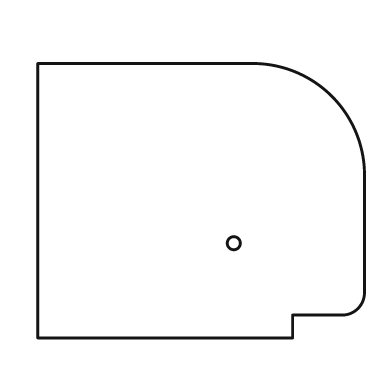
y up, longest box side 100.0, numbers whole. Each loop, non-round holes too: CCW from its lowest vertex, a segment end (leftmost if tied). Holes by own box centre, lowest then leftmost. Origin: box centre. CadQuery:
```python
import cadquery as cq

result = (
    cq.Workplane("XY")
    .moveTo(-50.0, -42.0)
    .lineTo(28.0, -42.0)
    .lineTo(28.0, -35.0)
    .lineTo(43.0, -35.0)
    .threePointArc((48.0, -33.0), (50.0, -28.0))
    .lineTo(50.0, 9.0)
    .threePointArc((40.0, 32.0), (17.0, 42.0))
    .lineTo(-50.0, 42.0)
    .close()
    .moveTo(10.0, -13.0)
    .circle(2.0)
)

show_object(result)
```